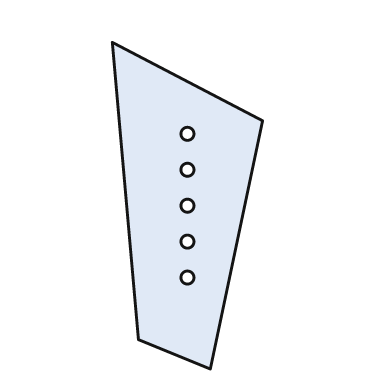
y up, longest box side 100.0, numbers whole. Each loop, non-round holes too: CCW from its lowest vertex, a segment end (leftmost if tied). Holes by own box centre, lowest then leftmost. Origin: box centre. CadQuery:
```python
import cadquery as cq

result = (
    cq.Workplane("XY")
    .moveTo(7.0, -50.0)
    .lineTo(23.0, 26.0)
    .lineTo(-23.0, 50.0)
    .lineTo(-15.0, -41.0)
    .close()
    .moveTo(0.0, -22.0)
    .circle(2.0)
    .moveTo(0.0, -11.0)
    .circle(2.0)
    .moveTo(0.0, 0.0)
    .circle(2.0)
    .moveTo(0.0, 11.0)
    .circle(2.0)
    .moveTo(0.0, 22.0)
    .circle(2.0)
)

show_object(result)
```